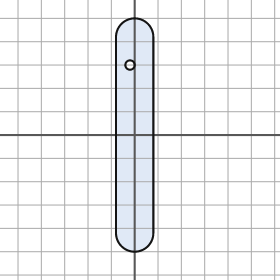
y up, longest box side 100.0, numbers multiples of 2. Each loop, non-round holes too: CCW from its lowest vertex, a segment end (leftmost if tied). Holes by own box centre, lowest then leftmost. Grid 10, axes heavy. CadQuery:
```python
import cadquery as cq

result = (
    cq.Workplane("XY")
    .moveTo(-8.0, -42.0)
    .threePointArc((0.0, -50.0), (8.0, -42.0))
    .lineTo(8.0, 42.0)
    .threePointArc((0.0, 50.0), (-8.0, 42.0))
    .close()
    .moveTo(-2.0, 30.0)
    .circle(2.0)
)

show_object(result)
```